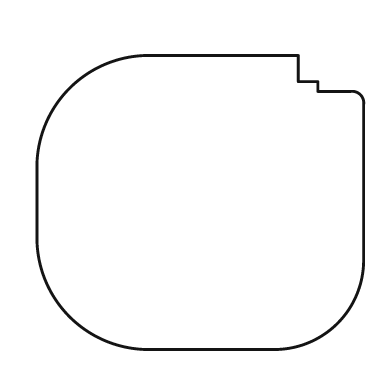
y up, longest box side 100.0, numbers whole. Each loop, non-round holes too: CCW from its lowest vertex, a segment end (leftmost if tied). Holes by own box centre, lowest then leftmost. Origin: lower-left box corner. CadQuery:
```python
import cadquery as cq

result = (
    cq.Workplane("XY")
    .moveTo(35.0, 0.0)
    .lineTo(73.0, 0.0)
    .threePointArc((92.0, 8.0), (100.0, 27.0))
    .lineTo(100.0, 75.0)
    .threePointArc((99.0, 78.0), (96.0, 79.0))
    .lineTo(86.0, 79.0)
    .lineTo(86.0, 82.0)
    .lineTo(80.0, 82.0)
    .lineTo(80.0, 90.0)
    .lineTo(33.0, 90.0)
    .threePointArc((10.0, 80.0), (0.0, 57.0))
    .lineTo(0.0, 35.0)
    .threePointArc((10.0, 10.0), (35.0, 0.0))
    .close()
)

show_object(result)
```